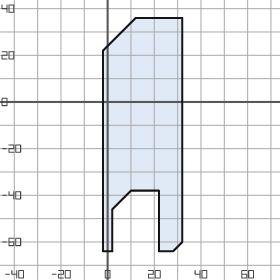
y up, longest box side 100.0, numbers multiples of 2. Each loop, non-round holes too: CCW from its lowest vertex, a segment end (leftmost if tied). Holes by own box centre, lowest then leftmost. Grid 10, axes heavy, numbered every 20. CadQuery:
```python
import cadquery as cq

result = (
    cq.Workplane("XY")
    .moveTo(-2.0, -64.0)
    .lineTo(2.0, -64.0)
    .lineTo(2.0, -46.0)
    .lineTo(10.0, -38.0)
    .lineTo(22.0, -38.0)
    .lineTo(22.0, -64.0)
    .lineTo(28.0, -64.0)
    .lineTo(32.0, -60.0)
    .lineTo(32.0, 36.0)
    .lineTo(12.0, 36.0)
    .lineTo(-2.0, 22.0)
    .close()
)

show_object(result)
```